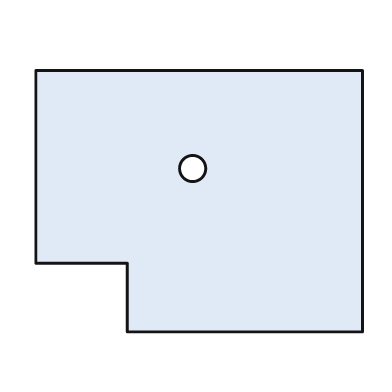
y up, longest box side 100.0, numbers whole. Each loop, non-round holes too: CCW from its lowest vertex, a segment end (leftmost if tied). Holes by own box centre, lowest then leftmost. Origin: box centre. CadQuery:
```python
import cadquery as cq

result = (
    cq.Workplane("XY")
    .moveTo(-22.0, -40.0)
    .lineTo(50.0, -40.0)
    .lineTo(50.0, 40.0)
    .lineTo(-50.0, 40.0)
    .lineTo(-50.0, -19.0)
    .lineTo(-22.0, -19.0)
    .close()
    .moveTo(-2.0, 10.0)
    .circle(4.0)
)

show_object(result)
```